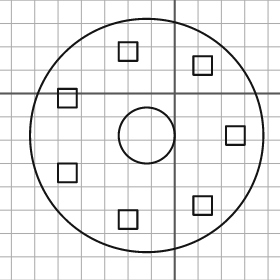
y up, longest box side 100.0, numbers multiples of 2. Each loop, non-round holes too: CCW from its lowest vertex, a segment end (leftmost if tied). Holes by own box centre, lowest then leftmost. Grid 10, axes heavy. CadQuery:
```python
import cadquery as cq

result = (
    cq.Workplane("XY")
    .moveTo(-12.0, -18.0)
    .circle(50.0)
    .moveTo(-24.0, -58.0)
    .lineTo(-16.0, -58.0)
    .lineTo(-16.0, -50.0)
    .lineTo(-24.0, -50.0)
    .close()
    .moveTo(8.0, -52.0)
    .lineTo(16.0, -52.0)
    .lineTo(16.0, -44.0)
    .lineTo(8.0, -44.0)
    .close()
    .moveTo(-50.0, -38.0)
    .lineTo(-42.0, -38.0)
    .lineTo(-42.0, -30.0)
    .lineTo(-50.0, -30.0)
    .close()
    .moveTo(-12.0, -18.0)
    .circle(12.0)
    .moveTo(22.0, -22.0)
    .lineTo(30.0, -22.0)
    .lineTo(30.0, -14.0)
    .lineTo(22.0, -14.0)
    .close()
    .moveTo(-50.0, -6.0)
    .lineTo(-42.0, -6.0)
    .lineTo(-42.0, 2.0)
    .lineTo(-50.0, 2.0)
    .close()
    .moveTo(8.0, 8.0)
    .lineTo(16.0, 8.0)
    .lineTo(16.0, 16.0)
    .lineTo(8.0, 16.0)
    .close()
    .moveTo(-24.0, 14.0)
    .lineTo(-16.0, 14.0)
    .lineTo(-16.0, 22.0)
    .lineTo(-24.0, 22.0)
    .close()
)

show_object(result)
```